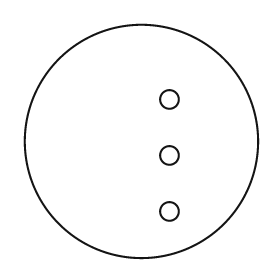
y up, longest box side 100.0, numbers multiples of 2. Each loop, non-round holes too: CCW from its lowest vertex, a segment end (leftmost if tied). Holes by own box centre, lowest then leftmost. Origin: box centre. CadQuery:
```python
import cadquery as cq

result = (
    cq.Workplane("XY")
    .moveTo(0.0, 0.0)
    .circle(50.0)
    .moveTo(12.0, -30.0)
    .circle(4.0)
    .moveTo(12.0, -6.0)
    .circle(4.0)
    .moveTo(12.0, 18.0)
    .circle(4.0)
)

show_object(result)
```